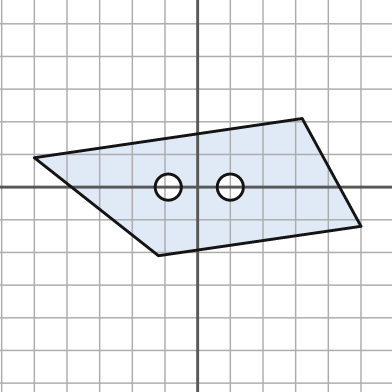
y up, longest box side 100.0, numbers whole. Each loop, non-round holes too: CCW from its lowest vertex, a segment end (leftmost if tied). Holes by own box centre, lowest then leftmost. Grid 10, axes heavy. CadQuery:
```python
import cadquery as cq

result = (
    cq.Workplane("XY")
    .moveTo(-12.0, -21.0)
    .lineTo(50.0, -12.0)
    .lineTo(32.0, 21.0)
    .lineTo(-50.0, 9.0)
    .close()
    .moveTo(-9.0, 0.0)
    .circle(4.0)
    .moveTo(10.0, 0.0)
    .circle(4.0)
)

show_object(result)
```